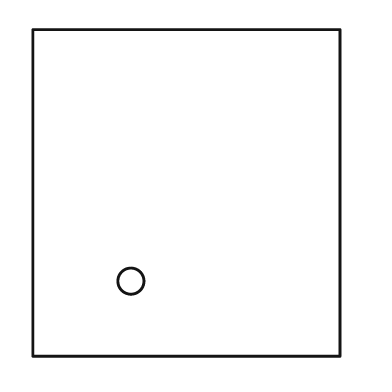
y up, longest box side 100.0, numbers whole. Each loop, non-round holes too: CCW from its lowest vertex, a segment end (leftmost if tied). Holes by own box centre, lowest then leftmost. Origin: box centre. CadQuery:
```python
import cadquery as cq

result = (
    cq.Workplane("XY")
    .moveTo(-47.0, -50.0)
    .lineTo(47.0, -50.0)
    .lineTo(47.0, 50.0)
    .lineTo(-47.0, 50.0)
    .close()
    .moveTo(-17.0, -27.0)
    .circle(4.0)
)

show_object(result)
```